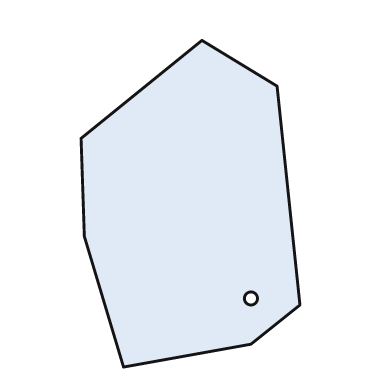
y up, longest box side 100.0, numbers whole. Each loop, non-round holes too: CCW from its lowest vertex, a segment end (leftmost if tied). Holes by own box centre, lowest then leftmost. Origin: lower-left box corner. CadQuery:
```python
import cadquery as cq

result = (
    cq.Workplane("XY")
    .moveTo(13.0, 0.0)
    .lineTo(52.0, 7.0)
    .lineTo(67.0, 19.0)
    .lineTo(60.0, 86.0)
    .lineTo(37.0, 100.0)
    .lineTo(0.0, 70.0)
    .lineTo(1.0, 40.0)
    .close()
    .moveTo(52.0, 21.0)
    .circle(2.0)
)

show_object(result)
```